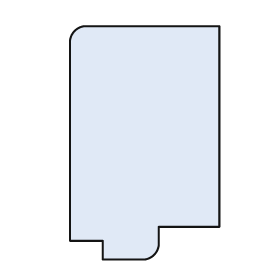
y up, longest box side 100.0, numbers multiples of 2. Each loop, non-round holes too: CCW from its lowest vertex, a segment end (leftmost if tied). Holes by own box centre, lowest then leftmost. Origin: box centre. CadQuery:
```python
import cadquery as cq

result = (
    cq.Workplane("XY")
    .moveTo(-18.0, -50.0)
    .lineTo(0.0, -50.0)
    .threePointArc((4.0, -48.0), (6.0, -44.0))
    .lineTo(6.0, -36.0)
    .lineTo(32.0, -36.0)
    .lineTo(32.0, 50.0)
    .lineTo(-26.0, 50.0)
    .threePointArc((-30.0, 48.0), (-32.0, 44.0))
    .lineTo(-32.0, -42.0)
    .lineTo(-18.0, -42.0)
    .close()
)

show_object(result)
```